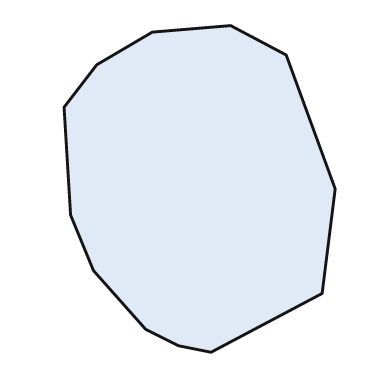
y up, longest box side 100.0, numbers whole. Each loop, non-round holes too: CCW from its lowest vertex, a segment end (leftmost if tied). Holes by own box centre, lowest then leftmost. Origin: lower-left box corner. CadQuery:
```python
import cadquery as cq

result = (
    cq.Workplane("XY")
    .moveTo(45.0, 0.0)
    .lineTo(79.0, 18.0)
    .lineTo(83.0, 50.0)
    .lineTo(68.0, 91.0)
    .lineTo(51.0, 100.0)
    .lineTo(27.0, 98.0)
    .lineTo(10.0, 88.0)
    .lineTo(0.0, 75.0)
    .lineTo(2.0, 42.0)
    .lineTo(9.0, 25.0)
    .lineTo(25.0, 7.0)
    .lineTo(35.0, 2.0)
    .close()
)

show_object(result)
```